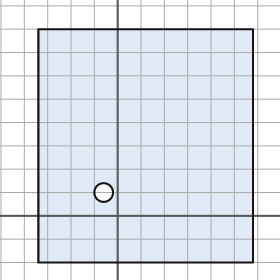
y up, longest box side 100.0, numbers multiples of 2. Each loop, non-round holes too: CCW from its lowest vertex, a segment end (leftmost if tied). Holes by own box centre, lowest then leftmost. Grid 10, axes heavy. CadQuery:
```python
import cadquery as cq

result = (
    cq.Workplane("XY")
    .moveTo(-34.0, -20.0)
    .lineTo(58.0, -20.0)
    .lineTo(58.0, 80.0)
    .lineTo(-34.0, 80.0)
    .close()
    .moveTo(-6.0, 10.0)
    .circle(4.0)
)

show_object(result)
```